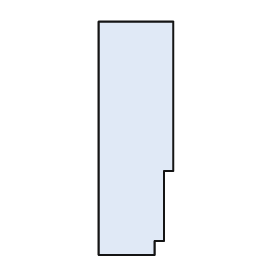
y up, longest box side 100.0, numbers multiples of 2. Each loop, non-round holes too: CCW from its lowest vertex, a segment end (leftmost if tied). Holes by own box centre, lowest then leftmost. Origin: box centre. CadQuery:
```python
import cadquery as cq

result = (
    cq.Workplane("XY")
    .moveTo(-16.0, -50.0)
    .lineTo(8.0, -50.0)
    .lineTo(8.0, -44.0)
    .lineTo(12.0, -44.0)
    .lineTo(12.0, -14.0)
    .lineTo(16.0, -14.0)
    .lineTo(16.0, 50.0)
    .lineTo(-16.0, 50.0)
    .close()
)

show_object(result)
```